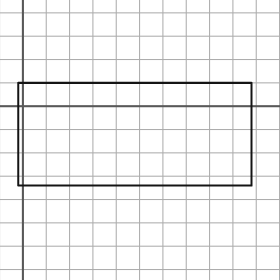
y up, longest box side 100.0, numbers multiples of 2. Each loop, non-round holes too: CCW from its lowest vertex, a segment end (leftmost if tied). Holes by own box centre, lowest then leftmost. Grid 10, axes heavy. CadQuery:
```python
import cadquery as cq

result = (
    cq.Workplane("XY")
    .moveTo(-2.0, -34.0)
    .lineTo(98.0, -34.0)
    .lineTo(98.0, 10.0)
    .lineTo(-2.0, 10.0)
    .close()
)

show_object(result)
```